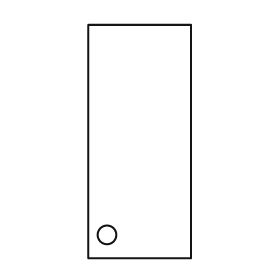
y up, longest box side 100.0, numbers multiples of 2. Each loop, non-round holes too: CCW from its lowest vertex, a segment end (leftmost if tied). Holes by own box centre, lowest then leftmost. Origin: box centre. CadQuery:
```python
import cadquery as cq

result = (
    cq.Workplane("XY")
    .moveTo(-22.0, -50.0)
    .lineTo(22.0, -50.0)
    .lineTo(22.0, 50.0)
    .lineTo(-22.0, 50.0)
    .close()
    .moveTo(-14.0, -40.0)
    .circle(4.0)
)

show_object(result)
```